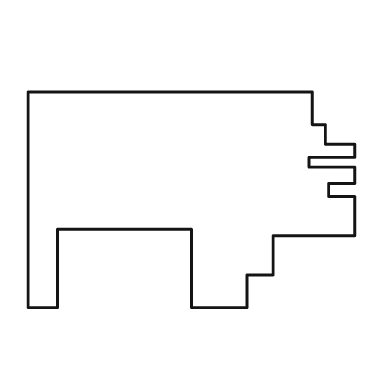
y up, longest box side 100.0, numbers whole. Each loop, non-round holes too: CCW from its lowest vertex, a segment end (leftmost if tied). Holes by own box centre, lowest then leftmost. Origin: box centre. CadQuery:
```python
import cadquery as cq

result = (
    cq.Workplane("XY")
    .moveTo(-50.0, -33.0)
    .lineTo(-41.0, -33.0)
    .lineTo(-41.0, -9.0)
    .lineTo(0.0, -9.0)
    .lineTo(0.0, -33.0)
    .lineTo(17.0, -33.0)
    .lineTo(17.0, -23.0)
    .lineTo(25.0, -23.0)
    .lineTo(25.0, -11.0)
    .lineTo(50.0, -11.0)
    .lineTo(50.0, 1.0)
    .lineTo(42.0, 1.0)
    .lineTo(42.0, 5.0)
    .lineTo(50.0, 5.0)
    .lineTo(50.0, 10.0)
    .lineTo(36.0, 10.0)
    .lineTo(36.0, 13.0)
    .lineTo(50.0, 13.0)
    .lineTo(50.0, 17.0)
    .lineTo(41.0, 17.0)
    .lineTo(41.0, 23.0)
    .lineTo(37.0, 23.0)
    .lineTo(37.0, 33.0)
    .lineTo(-50.0, 33.0)
    .close()
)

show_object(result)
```